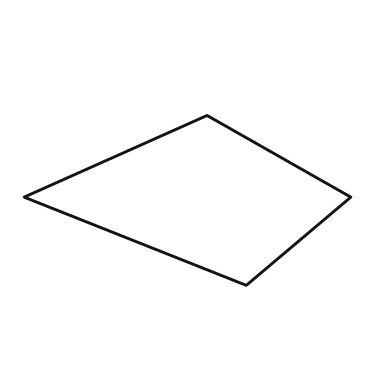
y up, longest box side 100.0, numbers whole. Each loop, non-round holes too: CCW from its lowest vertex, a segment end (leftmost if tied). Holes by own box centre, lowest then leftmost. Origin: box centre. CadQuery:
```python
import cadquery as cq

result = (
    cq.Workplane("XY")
    .moveTo(18.0, -26.0)
    .lineTo(50.0, 1.0)
    .lineTo(6.0, 26.0)
    .lineTo(-50.0, 1.0)
    .close()
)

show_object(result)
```